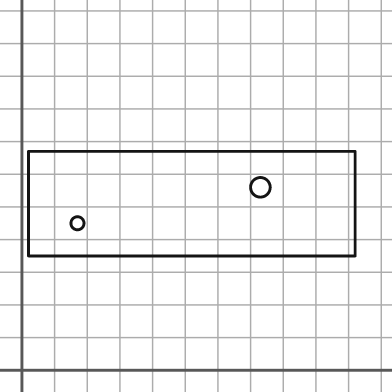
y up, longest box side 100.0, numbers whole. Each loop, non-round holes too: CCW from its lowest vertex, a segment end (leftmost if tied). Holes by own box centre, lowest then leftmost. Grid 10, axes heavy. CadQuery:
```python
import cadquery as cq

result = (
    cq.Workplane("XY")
    .moveTo(2.0, 35.0)
    .lineTo(102.0, 35.0)
    .lineTo(102.0, 67.0)
    .lineTo(2.0, 67.0)
    .close()
    .moveTo(17.0, 45.0)
    .circle(2.0)
    .moveTo(73.0, 56.0)
    .circle(3.0)
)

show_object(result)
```